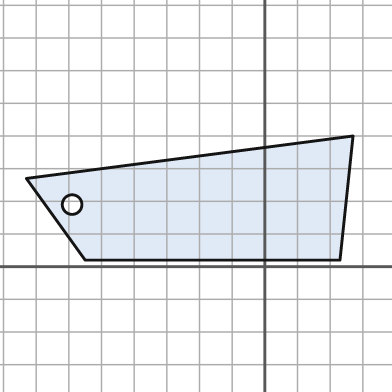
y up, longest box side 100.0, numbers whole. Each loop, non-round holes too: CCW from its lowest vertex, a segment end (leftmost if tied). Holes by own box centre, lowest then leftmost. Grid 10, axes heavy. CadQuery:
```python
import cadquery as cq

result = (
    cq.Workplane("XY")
    .moveTo(-55.0, 2.0)
    .lineTo(23.0, 2.0)
    .lineTo(27.0, 40.0)
    .lineTo(-73.0, 27.0)
    .close()
    .moveTo(-59.0, 19.0)
    .circle(3.0)
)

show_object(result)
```